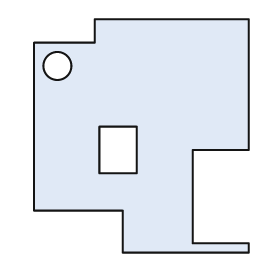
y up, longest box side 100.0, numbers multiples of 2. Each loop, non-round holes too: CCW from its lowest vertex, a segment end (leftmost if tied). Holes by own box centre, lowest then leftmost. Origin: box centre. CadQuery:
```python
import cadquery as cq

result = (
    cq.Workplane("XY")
    .moveTo(-8.0, -50.0)
    .lineTo(46.0, -50.0)
    .lineTo(46.0, -46.0)
    .lineTo(22.0, -46.0)
    .lineTo(22.0, -6.0)
    .lineTo(46.0, -6.0)
    .lineTo(46.0, 50.0)
    .lineTo(-20.0, 50.0)
    .lineTo(-20.0, 40.0)
    .lineTo(-46.0, 40.0)
    .lineTo(-46.0, -32.0)
    .lineTo(-8.0, -32.0)
    .close()
    .moveTo(-18.0, -16.0)
    .lineTo(-2.0, -16.0)
    .lineTo(-2.0, 4.0)
    .lineTo(-18.0, 4.0)
    .close()
    .moveTo(-36.0, 30.0)
    .circle(6.0)
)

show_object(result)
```